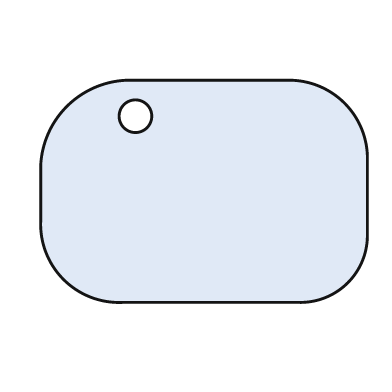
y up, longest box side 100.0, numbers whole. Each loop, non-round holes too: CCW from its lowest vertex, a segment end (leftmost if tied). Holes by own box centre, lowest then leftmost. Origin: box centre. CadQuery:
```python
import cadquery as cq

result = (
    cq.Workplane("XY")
    .moveTo(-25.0, -34.0)
    .lineTo(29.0, -34.0)
    .threePointArc((44.0, -28.0), (50.0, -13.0))
    .lineTo(50.0, 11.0)
    .threePointArc((43.0, 27.0), (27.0, 34.0))
    .lineTo(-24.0, 34.0)
    .threePointArc((-42.0, 26.0), (-50.0, 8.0))
    .lineTo(-50.0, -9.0)
    .threePointArc((-43.0, -27.0), (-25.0, -34.0))
    .close()
    .moveTo(-21.0, 23.0)
    .circle(5.0)
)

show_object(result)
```